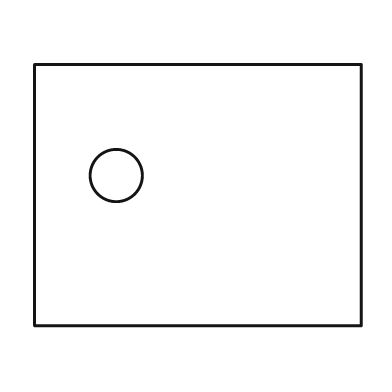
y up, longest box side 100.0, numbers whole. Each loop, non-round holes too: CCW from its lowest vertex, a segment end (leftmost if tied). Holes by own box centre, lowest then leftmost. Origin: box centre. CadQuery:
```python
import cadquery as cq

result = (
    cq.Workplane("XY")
    .moveTo(-50.0, -40.0)
    .lineTo(50.0, -40.0)
    .lineTo(50.0, 40.0)
    .lineTo(-50.0, 40.0)
    .close()
    .moveTo(-25.0, 6.0)
    .circle(8.0)
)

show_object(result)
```